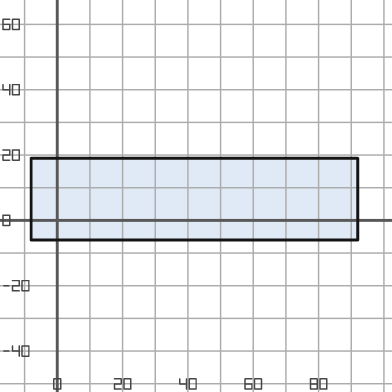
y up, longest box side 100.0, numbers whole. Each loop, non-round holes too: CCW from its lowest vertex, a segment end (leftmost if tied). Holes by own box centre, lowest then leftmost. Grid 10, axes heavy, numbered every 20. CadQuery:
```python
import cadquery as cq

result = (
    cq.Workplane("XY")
    .moveTo(-8.0, -6.0)
    .lineTo(92.0, -6.0)
    .lineTo(92.0, 19.0)
    .lineTo(-8.0, 19.0)
    .close()
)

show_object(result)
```